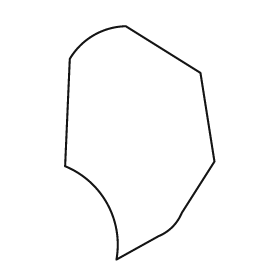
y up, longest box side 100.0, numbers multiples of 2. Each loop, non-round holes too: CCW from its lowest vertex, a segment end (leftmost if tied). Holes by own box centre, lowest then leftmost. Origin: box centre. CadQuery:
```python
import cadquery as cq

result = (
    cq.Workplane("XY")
    .moveTo(-10.0, -50.0)
    .lineTo(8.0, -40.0)
    .threePointArc((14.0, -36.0), (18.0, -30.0))
    .lineTo(32.0, -8.0)
    .lineTo(26.0, 30.0)
    .lineTo(-6.0, 50.0)
    .threePointArc((-20.0, 46.0), (-30.0, 36.0))
    .lineTo(-32.0, -10.0)
    .threePointArc((-14.0, -26.0), (-10.0, -50.0))
    .close()
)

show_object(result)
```